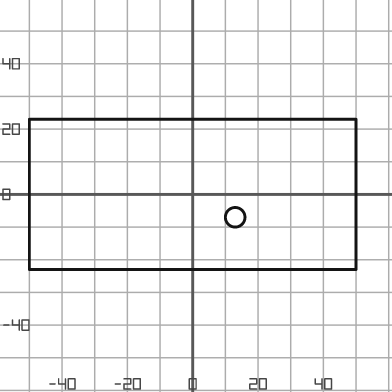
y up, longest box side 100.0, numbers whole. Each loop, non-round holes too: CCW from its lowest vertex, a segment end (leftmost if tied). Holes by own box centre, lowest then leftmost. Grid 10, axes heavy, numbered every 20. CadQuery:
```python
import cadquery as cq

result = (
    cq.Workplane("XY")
    .moveTo(-50.0, -23.0)
    .lineTo(50.0, -23.0)
    .lineTo(50.0, 23.0)
    .lineTo(-50.0, 23.0)
    .close()
    .moveTo(13.0, -7.0)
    .circle(3.0)
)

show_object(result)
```